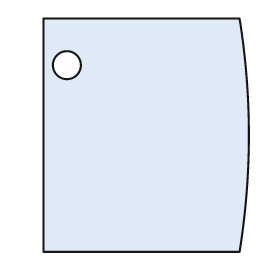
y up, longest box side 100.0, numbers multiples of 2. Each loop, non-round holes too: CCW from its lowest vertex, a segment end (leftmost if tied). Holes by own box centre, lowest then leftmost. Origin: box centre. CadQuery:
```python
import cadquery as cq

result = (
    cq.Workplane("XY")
    .moveTo(-44.0, -50.0)
    .lineTo(40.0, -50.0)
    .threePointArc((44.0, 0.0), (40.0, 50.0))
    .lineTo(-44.0, 50.0)
    .close()
    .moveTo(-34.0, 30.0)
    .circle(6.0)
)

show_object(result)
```